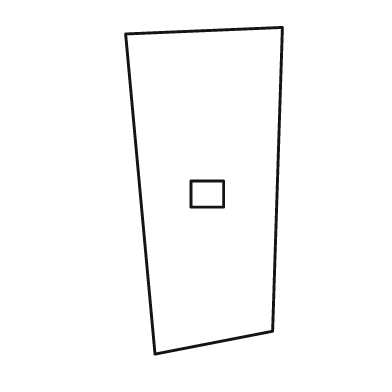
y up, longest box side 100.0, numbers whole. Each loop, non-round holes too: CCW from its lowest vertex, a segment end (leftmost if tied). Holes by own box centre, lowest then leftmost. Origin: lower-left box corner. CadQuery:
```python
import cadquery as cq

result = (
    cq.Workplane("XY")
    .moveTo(9.0, 0.0)
    .lineTo(45.0, 7.0)
    .lineTo(48.0, 100.0)
    .lineTo(0.0, 98.0)
    .close()
    .moveTo(20.0, 45.0)
    .lineTo(30.0, 45.0)
    .lineTo(30.0, 53.0)
    .lineTo(20.0, 53.0)
    .close()
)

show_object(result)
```